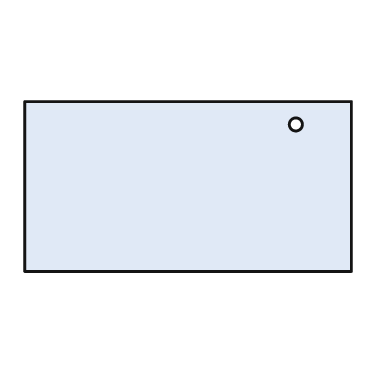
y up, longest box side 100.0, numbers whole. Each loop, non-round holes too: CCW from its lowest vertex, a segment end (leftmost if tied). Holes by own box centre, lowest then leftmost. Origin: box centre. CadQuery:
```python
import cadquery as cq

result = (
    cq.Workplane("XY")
    .moveTo(-50.0, -26.0)
    .lineTo(50.0, -26.0)
    .lineTo(50.0, 26.0)
    .lineTo(-50.0, 26.0)
    .close()
    .moveTo(33.0, 19.0)
    .circle(2.0)
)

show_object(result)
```